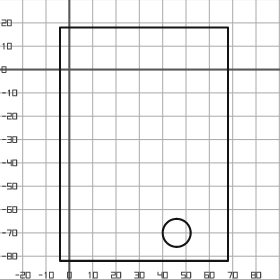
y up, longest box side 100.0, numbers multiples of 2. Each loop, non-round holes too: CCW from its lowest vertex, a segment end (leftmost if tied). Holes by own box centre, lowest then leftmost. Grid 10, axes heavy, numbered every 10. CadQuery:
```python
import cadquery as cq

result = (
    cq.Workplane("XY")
    .moveTo(-4.0, -82.0)
    .lineTo(68.0, -82.0)
    .lineTo(68.0, 18.0)
    .lineTo(-4.0, 18.0)
    .close()
    .moveTo(46.0, -70.0)
    .circle(6.0)
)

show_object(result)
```